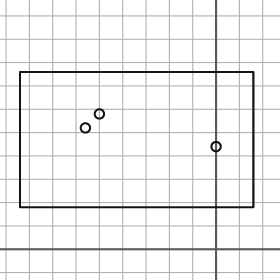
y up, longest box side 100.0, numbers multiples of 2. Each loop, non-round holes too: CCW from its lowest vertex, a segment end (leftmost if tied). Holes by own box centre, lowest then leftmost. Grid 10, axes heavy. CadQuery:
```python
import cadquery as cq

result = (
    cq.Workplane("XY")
    .moveTo(-84.0, 18.0)
    .lineTo(16.0, 18.0)
    .lineTo(16.0, 76.0)
    .lineTo(-84.0, 76.0)
    .close()
    .moveTo(0.0, 44.0)
    .circle(2.0)
    .moveTo(-56.0, 52.0)
    .circle(2.0)
    .moveTo(-50.0, 58.0)
    .circle(2.0)
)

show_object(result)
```